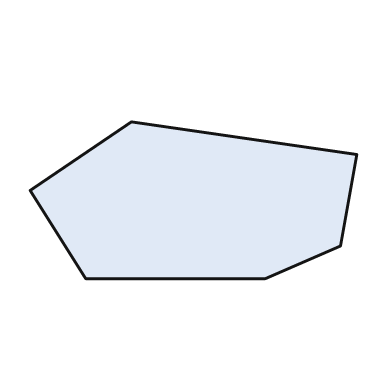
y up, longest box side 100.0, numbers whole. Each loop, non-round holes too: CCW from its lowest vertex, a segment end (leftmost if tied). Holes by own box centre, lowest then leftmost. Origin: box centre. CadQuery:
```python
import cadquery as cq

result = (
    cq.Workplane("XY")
    .moveTo(-33.0, -24.0)
    .lineTo(22.0, -24.0)
    .lineTo(45.0, -14.0)
    .lineTo(50.0, 14.0)
    .lineTo(-19.0, 24.0)
    .lineTo(-50.0, 3.0)
    .close()
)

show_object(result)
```